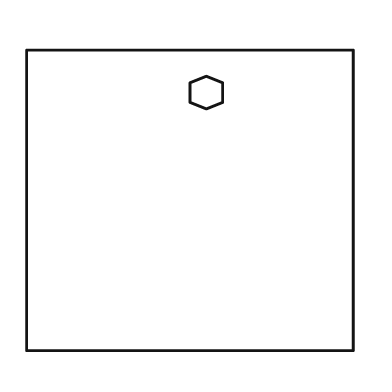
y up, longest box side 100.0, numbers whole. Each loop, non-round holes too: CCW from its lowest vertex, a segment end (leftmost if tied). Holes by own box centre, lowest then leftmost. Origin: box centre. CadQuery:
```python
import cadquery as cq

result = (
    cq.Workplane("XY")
    .moveTo(-50.0, -46.0)
    .lineTo(50.0, -46.0)
    .lineTo(50.0, 46.0)
    .lineTo(-50.0, 46.0)
    .close()
    .moveTo(5.0, 28.0)
    .lineTo(10.0, 30.0)
    .lineTo(10.0, 36.0)
    .lineTo(5.0, 38.0)
    .lineTo(0.0, 36.0)
    .lineTo(0.0, 30.0)
    .close()
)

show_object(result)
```